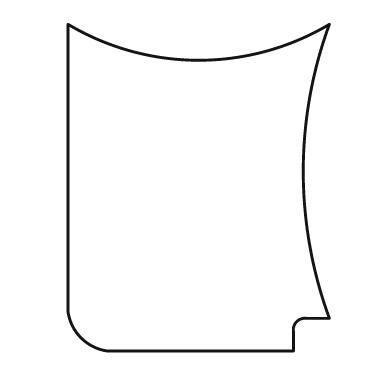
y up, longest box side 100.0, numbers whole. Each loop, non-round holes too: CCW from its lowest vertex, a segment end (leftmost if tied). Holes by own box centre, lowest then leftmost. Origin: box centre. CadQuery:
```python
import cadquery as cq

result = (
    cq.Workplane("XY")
    .moveTo(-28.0, -50.0)
    .lineTo(29.0, -50.0)
    .lineTo(29.0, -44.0)
    .threePointArc((30.0, -41.0), (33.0, -40.0))
    .lineTo(40.0, -40.0)
    .threePointArc((32.0, 5.0), (40.0, 50.0))
    .threePointArc((0.0, 39.0), (-40.0, 50.0))
    .lineTo(-40.0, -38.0)
    .threePointArc((-36.0, -46.0), (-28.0, -50.0))
    .close()
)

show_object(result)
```